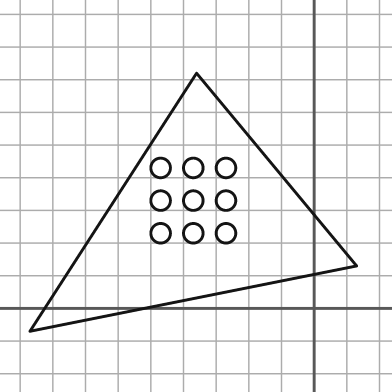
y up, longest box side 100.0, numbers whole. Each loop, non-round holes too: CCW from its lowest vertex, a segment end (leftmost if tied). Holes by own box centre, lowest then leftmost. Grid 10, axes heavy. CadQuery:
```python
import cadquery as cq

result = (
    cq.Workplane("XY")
    .moveTo(-87.0, -7.0)
    .lineTo(13.0, 13.0)
    .lineTo(-36.0, 72.0)
    .close()
    .moveTo(-47.0, 23.0)
    .circle(3.0)
    .moveTo(-37.0, 23.0)
    .circle(3.0)
    .moveTo(-27.0, 23.0)
    .circle(3.0)
    .moveTo(-47.0, 33.0)
    .circle(3.0)
    .moveTo(-37.0, 33.0)
    .circle(3.0)
    .moveTo(-27.0, 33.0)
    .circle(3.0)
    .moveTo(-47.0, 43.0)
    .circle(3.0)
    .moveTo(-37.0, 43.0)
    .circle(3.0)
    .moveTo(-27.0, 43.0)
    .circle(3.0)
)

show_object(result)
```